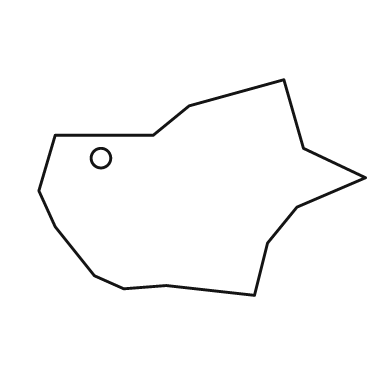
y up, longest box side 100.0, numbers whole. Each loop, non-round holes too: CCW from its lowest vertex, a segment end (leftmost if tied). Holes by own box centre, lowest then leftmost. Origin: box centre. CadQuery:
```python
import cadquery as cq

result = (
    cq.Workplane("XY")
    .moveTo(16.0, -33.0)
    .lineTo(20.0, -17.0)
    .lineTo(29.0, -6.0)
    .lineTo(50.0, 3.0)
    .lineTo(31.0, 12.0)
    .lineTo(25.0, 33.0)
    .lineTo(-4.0, 25.0)
    .lineTo(-15.0, 16.0)
    .lineTo(-45.0, 16.0)
    .lineTo(-50.0, -1.0)
    .lineTo(-45.0, -12.0)
    .lineTo(-33.0, -27.0)
    .lineTo(-24.0, -31.0)
    .lineTo(-11.0, -30.0)
    .close()
    .moveTo(-31.0, 9.0)
    .circle(3.0)
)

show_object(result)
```